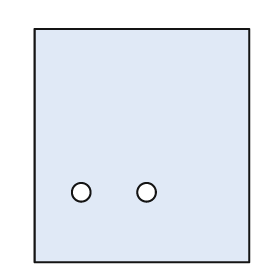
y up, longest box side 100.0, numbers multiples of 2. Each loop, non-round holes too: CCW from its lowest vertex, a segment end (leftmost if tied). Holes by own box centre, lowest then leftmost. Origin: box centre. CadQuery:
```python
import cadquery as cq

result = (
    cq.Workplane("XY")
    .moveTo(-46.0, -50.0)
    .lineTo(46.0, -50.0)
    .lineTo(46.0, 50.0)
    .lineTo(-46.0, 50.0)
    .close()
    .moveTo(-26.0, -20.0)
    .circle(4.0)
    .moveTo(2.0, -20.0)
    .circle(4.0)
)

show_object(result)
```